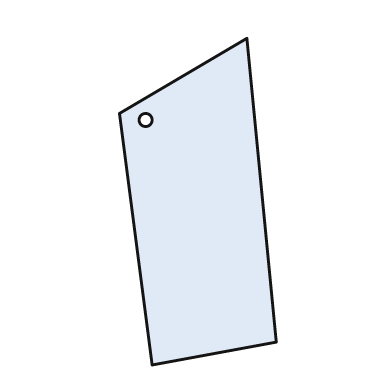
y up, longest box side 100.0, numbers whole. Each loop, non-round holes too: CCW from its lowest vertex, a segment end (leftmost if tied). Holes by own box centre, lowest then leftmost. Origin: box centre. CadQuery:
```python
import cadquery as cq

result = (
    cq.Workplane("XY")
    .moveTo(-14.0, -50.0)
    .lineTo(24.0, -43.0)
    .lineTo(15.0, 50.0)
    .lineTo(-24.0, 27.0)
    .close()
    .moveTo(-16.0, 25.0)
    .circle(2.0)
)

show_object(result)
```